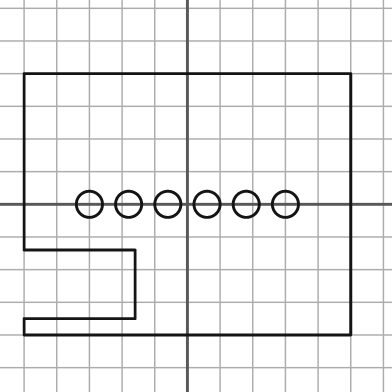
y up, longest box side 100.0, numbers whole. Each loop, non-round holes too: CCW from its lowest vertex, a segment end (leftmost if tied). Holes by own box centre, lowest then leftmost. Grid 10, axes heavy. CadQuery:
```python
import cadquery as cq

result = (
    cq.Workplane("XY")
    .moveTo(-50.0, -40.0)
    .lineTo(50.0, -40.0)
    .lineTo(50.0, 40.0)
    .lineTo(-50.0, 40.0)
    .lineTo(-50.0, -14.0)
    .lineTo(-16.0, -14.0)
    .lineTo(-16.0, -35.0)
    .lineTo(-50.0, -35.0)
    .close()
    .moveTo(-30.0, 0.0)
    .circle(4.0)
    .moveTo(-18.0, 0.0)
    .circle(4.0)
    .moveTo(-6.0, 0.0)
    .circle(4.0)
    .moveTo(6.0, 0.0)
    .circle(4.0)
    .moveTo(18.0, 0.0)
    .circle(4.0)
    .moveTo(30.0, 0.0)
    .circle(4.0)
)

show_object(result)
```